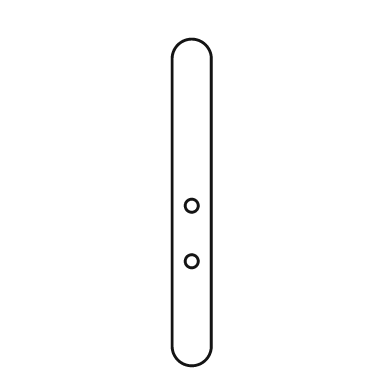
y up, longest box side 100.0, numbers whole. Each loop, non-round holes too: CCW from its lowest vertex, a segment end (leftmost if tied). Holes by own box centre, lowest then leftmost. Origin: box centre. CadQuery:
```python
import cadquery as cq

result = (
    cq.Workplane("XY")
    .moveTo(-6.0, -44.0)
    .threePointArc((0.0, -50.0), (6.0, -44.0))
    .lineTo(6.0, 44.0)
    .threePointArc((0.0, 50.0), (-6.0, 44.0))
    .close()
    .moveTo(0.0, -18.0)
    .circle(2.0)
    .moveTo(0.0, -1.0)
    .circle(2.0)
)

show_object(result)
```